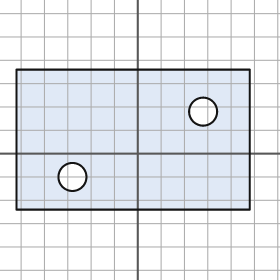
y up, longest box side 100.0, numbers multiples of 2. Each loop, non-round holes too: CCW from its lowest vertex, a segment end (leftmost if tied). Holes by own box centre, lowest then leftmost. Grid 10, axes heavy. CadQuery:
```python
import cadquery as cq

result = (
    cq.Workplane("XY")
    .moveTo(-52.0, -24.0)
    .lineTo(48.0, -24.0)
    .lineTo(48.0, 36.0)
    .lineTo(-52.0, 36.0)
    .close()
    .moveTo(-28.0, -10.0)
    .circle(6.0)
    .moveTo(28.0, 18.0)
    .circle(6.0)
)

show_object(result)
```